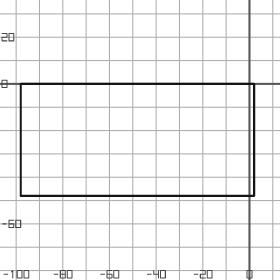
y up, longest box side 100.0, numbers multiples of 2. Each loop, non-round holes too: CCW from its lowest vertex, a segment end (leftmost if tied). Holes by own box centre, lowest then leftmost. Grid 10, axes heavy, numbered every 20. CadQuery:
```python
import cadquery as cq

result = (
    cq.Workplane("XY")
    .moveTo(-98.0, -48.0)
    .lineTo(2.0, -48.0)
    .lineTo(2.0, 0.0)
    .lineTo(-98.0, 0.0)
    .close()
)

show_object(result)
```